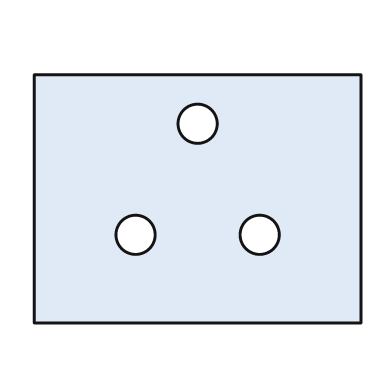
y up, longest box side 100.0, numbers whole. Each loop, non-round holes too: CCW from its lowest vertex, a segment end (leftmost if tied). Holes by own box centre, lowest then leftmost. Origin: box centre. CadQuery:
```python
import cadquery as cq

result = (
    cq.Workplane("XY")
    .moveTo(-50.0, -38.0)
    .lineTo(50.0, -38.0)
    .lineTo(50.0, 38.0)
    .lineTo(-50.0, 38.0)
    .close()
    .moveTo(-19.0, -11.0)
    .circle(6.0)
    .moveTo(19.0, -11.0)
    .circle(6.0)
    .moveTo(0.0, 23.0)
    .circle(6.0)
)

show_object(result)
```